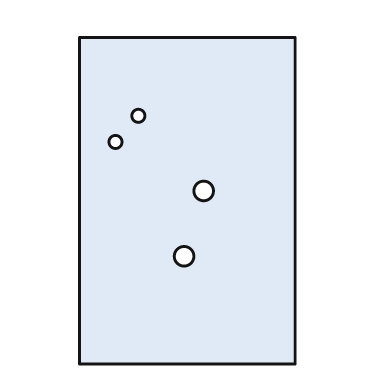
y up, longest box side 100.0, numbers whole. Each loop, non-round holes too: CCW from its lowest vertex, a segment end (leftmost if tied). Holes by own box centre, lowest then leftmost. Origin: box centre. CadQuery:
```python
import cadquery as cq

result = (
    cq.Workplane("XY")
    .moveTo(-33.0, -50.0)
    .lineTo(33.0, -50.0)
    .lineTo(33.0, 50.0)
    .lineTo(-33.0, 50.0)
    .close()
    .moveTo(-1.0, -17.0)
    .circle(3.0)
    .moveTo(5.0, 3.0)
    .circle(3.0)
    .moveTo(-22.0, 18.0)
    .circle(2.0)
    .moveTo(-15.0, 26.0)
    .circle(2.0)
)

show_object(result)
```